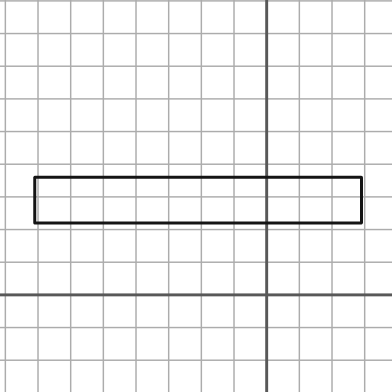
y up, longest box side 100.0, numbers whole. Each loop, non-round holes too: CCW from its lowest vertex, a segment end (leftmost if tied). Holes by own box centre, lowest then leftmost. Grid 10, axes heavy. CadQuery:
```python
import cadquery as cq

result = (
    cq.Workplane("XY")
    .moveTo(-71.0, 22.0)
    .lineTo(29.0, 22.0)
    .lineTo(29.0, 36.0)
    .lineTo(-71.0, 36.0)
    .close()
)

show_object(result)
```